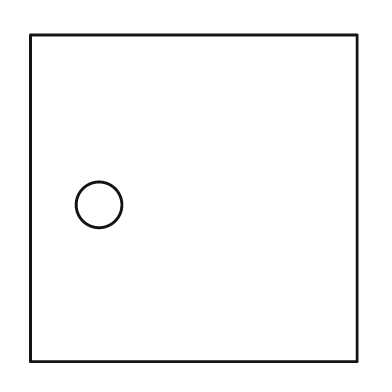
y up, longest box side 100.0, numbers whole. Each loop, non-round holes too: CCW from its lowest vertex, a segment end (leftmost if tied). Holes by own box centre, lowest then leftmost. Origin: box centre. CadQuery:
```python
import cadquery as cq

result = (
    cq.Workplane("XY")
    .moveTo(-50.0, -50.0)
    .lineTo(50.0, -50.0)
    .lineTo(50.0, 50.0)
    .lineTo(-50.0, 50.0)
    .close()
    .moveTo(-29.0, -2.0)
    .circle(7.0)
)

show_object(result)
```